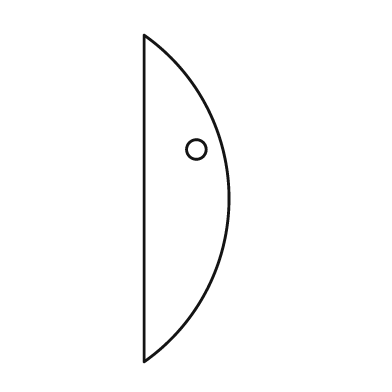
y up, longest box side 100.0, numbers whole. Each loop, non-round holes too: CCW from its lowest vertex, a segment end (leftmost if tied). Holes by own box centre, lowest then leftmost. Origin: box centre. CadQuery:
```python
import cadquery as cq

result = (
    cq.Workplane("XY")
    .moveTo(-13.0, -50.0)
    .threePointArc((13.0, 0.0), (-13.0, 50.0))
    .close()
    .moveTo(3.0, 15.0)
    .circle(3.0)
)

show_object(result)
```